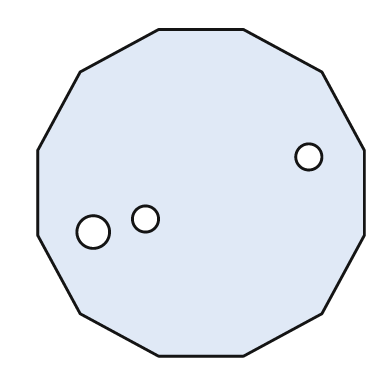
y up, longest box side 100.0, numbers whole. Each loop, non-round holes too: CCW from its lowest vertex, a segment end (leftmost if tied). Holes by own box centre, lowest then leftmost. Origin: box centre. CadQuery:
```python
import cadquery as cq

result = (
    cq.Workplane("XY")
    .moveTo(-13.0, -50.0)
    .lineTo(13.0, -50.0)
    .lineTo(37.0, -37.0)
    .lineTo(50.0, -13.0)
    .lineTo(50.0, 13.0)
    .lineTo(37.0, 37.0)
    .lineTo(13.0, 50.0)
    .lineTo(-13.0, 50.0)
    .lineTo(-37.0, 37.0)
    .lineTo(-50.0, 13.0)
    .lineTo(-50.0, -13.0)
    .lineTo(-37.0, -37.0)
    .close()
    .moveTo(-33.0, -12.0)
    .circle(5.0)
    .moveTo(-17.0, -8.0)
    .circle(4.0)
    .moveTo(33.0, 11.0)
    .circle(4.0)
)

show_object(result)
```